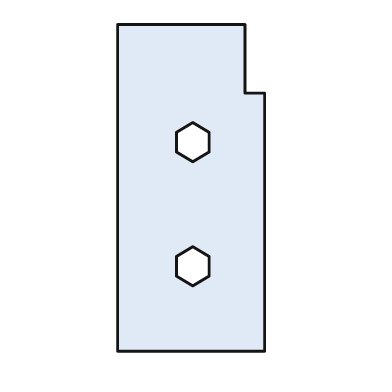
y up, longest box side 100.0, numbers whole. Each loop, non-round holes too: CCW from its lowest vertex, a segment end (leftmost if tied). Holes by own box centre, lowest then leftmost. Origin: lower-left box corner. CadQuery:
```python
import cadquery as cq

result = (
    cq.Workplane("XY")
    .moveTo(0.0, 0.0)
    .lineTo(45.0, 0.0)
    .lineTo(45.0, 79.0)
    .lineTo(39.0, 79.0)
    .lineTo(39.0, 100.0)
    .lineTo(0.0, 100.0)
    .close()
    .moveTo(23.0, 20.0)
    .lineTo(28.0, 23.0)
    .lineTo(28.0, 29.0)
    .lineTo(23.0, 32.0)
    .lineTo(18.0, 29.0)
    .lineTo(18.0, 23.0)
    .close()
    .moveTo(23.0, 58.0)
    .lineTo(28.0, 61.0)
    .lineTo(28.0, 67.0)
    .lineTo(23.0, 70.0)
    .lineTo(18.0, 67.0)
    .lineTo(18.0, 61.0)
    .close()
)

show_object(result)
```